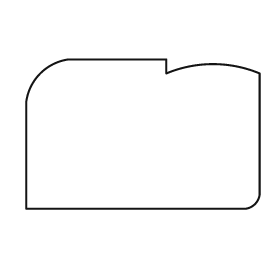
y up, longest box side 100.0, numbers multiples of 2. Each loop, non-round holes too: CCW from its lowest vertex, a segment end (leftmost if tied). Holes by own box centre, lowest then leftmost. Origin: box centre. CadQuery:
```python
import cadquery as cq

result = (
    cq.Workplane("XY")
    .moveTo(-50.0, -32.0)
    .lineTo(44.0, -32.0)
    .threePointArc((48.0, -30.0), (50.0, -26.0))
    .lineTo(50.0, 26.0)
    .threePointArc((30.0, 30.0), (10.0, 26.0))
    .lineTo(10.0, 32.0)
    .lineTo(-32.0, 32.0)
    .threePointArc((-44.0, 26.0), (-50.0, 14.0))
    .close()
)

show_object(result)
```